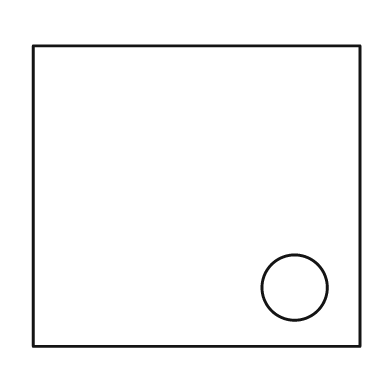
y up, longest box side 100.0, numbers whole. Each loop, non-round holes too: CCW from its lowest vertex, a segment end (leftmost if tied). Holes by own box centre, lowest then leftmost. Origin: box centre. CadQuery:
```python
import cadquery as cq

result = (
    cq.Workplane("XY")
    .moveTo(-50.0, -46.0)
    .lineTo(50.0, -46.0)
    .lineTo(50.0, 46.0)
    .lineTo(-50.0, 46.0)
    .close()
    .moveTo(30.0, -28.0)
    .circle(10.0)
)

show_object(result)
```